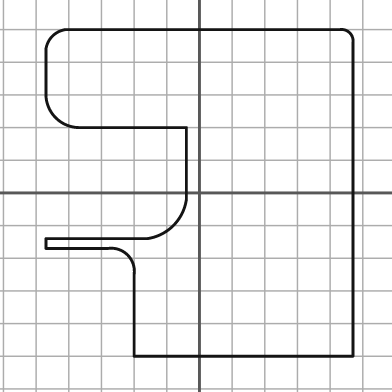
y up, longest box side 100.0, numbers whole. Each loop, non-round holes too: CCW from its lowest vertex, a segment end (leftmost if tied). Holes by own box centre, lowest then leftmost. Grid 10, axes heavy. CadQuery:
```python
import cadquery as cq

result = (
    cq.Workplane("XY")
    .moveTo(-20.0, -50.0)
    .lineTo(47.0, -50.0)
    .lineTo(47.0, 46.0)
    .threePointArc((46.0, 49.0), (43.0, 50.0))
    .lineTo(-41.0, 50.0)
    .threePointArc((-45.0, 48.0), (-47.0, 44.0))
    .lineTo(-47.0, 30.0)
    .threePointArc((-44.0, 23.0), (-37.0, 20.0))
    .lineTo(-4.0, 20.0)
    .lineTo(-4.0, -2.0)
    .threePointArc((-8.0, -10.0), (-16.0, -14.0))
    .lineTo(-47.0, -14.0)
    .lineTo(-47.0, -17.0)
    .lineTo(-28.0, -17.0)
    .threePointArc((-22.0, -19.0), (-20.0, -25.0))
    .close()
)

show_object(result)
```